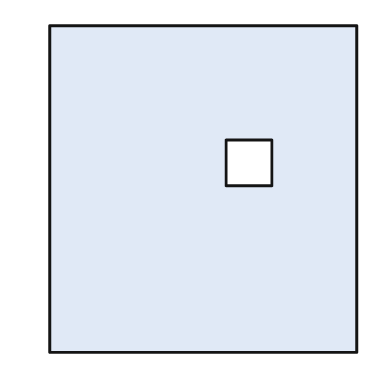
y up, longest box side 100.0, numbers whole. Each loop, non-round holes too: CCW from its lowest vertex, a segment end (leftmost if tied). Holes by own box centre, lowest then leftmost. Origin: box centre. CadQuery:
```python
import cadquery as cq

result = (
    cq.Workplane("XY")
    .moveTo(-47.0, -50.0)
    .lineTo(47.0, -50.0)
    .lineTo(47.0, 50.0)
    .lineTo(-47.0, 50.0)
    .close()
    .moveTo(7.0, 1.0)
    .lineTo(21.0, 1.0)
    .lineTo(21.0, 15.0)
    .lineTo(7.0, 15.0)
    .close()
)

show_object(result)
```